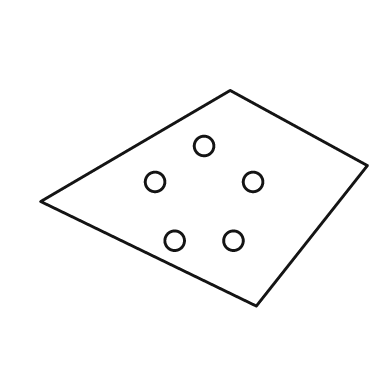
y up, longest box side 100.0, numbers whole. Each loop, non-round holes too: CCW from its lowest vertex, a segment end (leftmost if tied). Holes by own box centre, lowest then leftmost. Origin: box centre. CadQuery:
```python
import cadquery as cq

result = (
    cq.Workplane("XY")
    .moveTo(16.0, -33.0)
    .lineTo(50.0, 10.0)
    .lineTo(8.0, 33.0)
    .lineTo(-50.0, -1.0)
    .close()
    .moveTo(-9.0, -13.0)
    .circle(3.0)
    .moveTo(9.0, -13.0)
    .circle(3.0)
    .moveTo(-15.0, 5.0)
    .circle(3.0)
    .moveTo(15.0, 5.0)
    .circle(3.0)
    .moveTo(0.0, 16.0)
    .circle(3.0)
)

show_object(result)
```